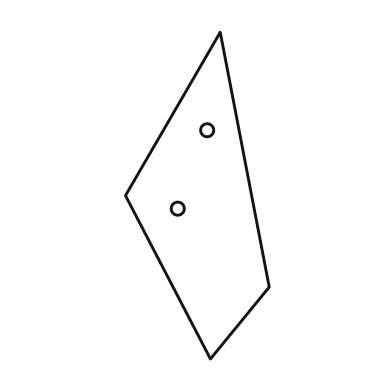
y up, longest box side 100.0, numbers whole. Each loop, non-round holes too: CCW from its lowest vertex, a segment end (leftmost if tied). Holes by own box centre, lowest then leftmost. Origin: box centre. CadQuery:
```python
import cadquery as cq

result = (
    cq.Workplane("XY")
    .moveTo(4.0, -50.0)
    .lineTo(22.0, -28.0)
    .lineTo(7.0, 50.0)
    .lineTo(-22.0, 0.0)
    .close()
    .moveTo(-6.0, -4.0)
    .circle(2.0)
    .moveTo(3.0, 20.0)
    .circle(2.0)
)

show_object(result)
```